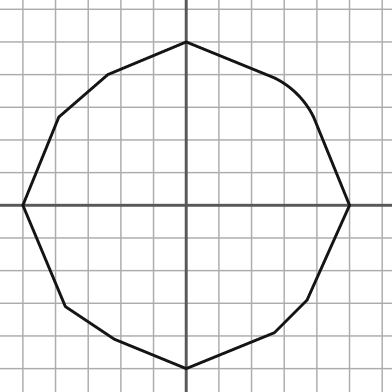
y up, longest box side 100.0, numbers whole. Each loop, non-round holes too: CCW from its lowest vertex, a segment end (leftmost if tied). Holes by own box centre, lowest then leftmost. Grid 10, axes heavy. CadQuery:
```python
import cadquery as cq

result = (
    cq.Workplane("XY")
    .moveTo(0.0, -50.0)
    .lineTo(27.0, -39.0)
    .lineTo(37.0, -29.0)
    .lineTo(50.0, 0.0)
    .lineTo(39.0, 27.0)
    .threePointArc((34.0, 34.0), (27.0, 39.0))
    .lineTo(0.0, 50.0)
    .lineTo(-24.0, 40.0)
    .lineTo(-39.0, 27.0)
    .lineTo(-50.0, 0.0)
    .lineTo(-37.0, -31.0)
    .lineTo(-22.0, -41.0)
    .close()
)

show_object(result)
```